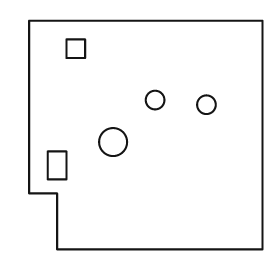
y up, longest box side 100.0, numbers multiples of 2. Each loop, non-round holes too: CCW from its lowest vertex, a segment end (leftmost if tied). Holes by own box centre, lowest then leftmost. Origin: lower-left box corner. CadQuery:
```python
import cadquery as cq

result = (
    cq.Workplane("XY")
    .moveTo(12.0, 0.0)
    .lineTo(100.0, 0.0)
    .lineTo(100.0, 98.0)
    .lineTo(0.0, 98.0)
    .lineTo(0.0, 24.0)
    .lineTo(12.0, 24.0)
    .close()
    .moveTo(8.0, 30.0)
    .lineTo(16.0, 30.0)
    .lineTo(16.0, 42.0)
    .lineTo(8.0, 42.0)
    .close()
    .moveTo(36.0, 46.0)
    .circle(6.0)
    .moveTo(76.0, 62.0)
    .circle(4.0)
    .moveTo(54.0, 64.0)
    .circle(4.0)
    .moveTo(16.0, 82.0)
    .lineTo(24.0, 82.0)
    .lineTo(24.0, 90.0)
    .lineTo(16.0, 90.0)
    .close()
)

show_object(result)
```